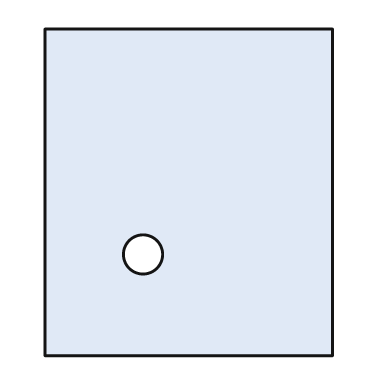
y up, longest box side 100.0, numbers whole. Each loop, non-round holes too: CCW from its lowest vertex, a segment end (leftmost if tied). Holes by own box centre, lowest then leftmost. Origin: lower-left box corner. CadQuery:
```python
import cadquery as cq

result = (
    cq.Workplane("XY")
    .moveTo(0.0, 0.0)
    .lineTo(88.0, 0.0)
    .lineTo(88.0, 100.0)
    .lineTo(0.0, 100.0)
    .close()
    .moveTo(30.0, 31.0)
    .circle(6.0)
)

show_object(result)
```